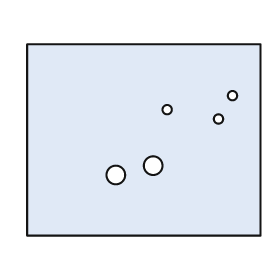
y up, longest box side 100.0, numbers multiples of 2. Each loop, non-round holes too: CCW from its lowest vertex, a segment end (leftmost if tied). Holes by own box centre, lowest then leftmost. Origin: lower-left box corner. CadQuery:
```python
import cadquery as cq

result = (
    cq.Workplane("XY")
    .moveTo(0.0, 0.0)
    .lineTo(100.0, 0.0)
    .lineTo(100.0, 82.0)
    .lineTo(0.0, 82.0)
    .close()
    .moveTo(38.0, 26.0)
    .circle(4.0)
    .moveTo(54.0, 30.0)
    .circle(4.0)
    .moveTo(82.0, 50.0)
    .circle(2.0)
    .moveTo(60.0, 54.0)
    .circle(2.0)
    .moveTo(88.0, 60.0)
    .circle(2.0)
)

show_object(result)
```